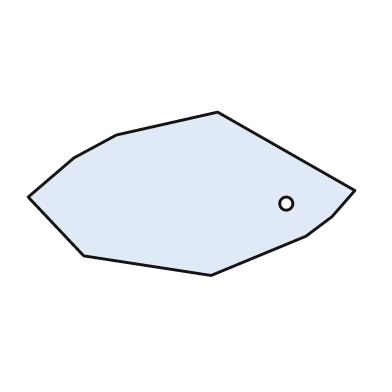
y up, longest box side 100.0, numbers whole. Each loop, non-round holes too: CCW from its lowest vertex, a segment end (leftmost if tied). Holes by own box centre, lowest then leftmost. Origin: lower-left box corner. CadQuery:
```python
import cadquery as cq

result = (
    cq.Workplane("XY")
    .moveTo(56.0, 0.0)
    .lineTo(85.0, 12.0)
    .lineTo(93.0, 18.0)
    .lineTo(100.0, 26.0)
    .lineTo(58.0, 50.0)
    .lineTo(27.0, 43.0)
    .lineTo(14.0, 36.0)
    .lineTo(0.0, 24.0)
    .lineTo(17.0, 6.0)
    .close()
    .moveTo(79.0, 22.0)
    .circle(2.0)
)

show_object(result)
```